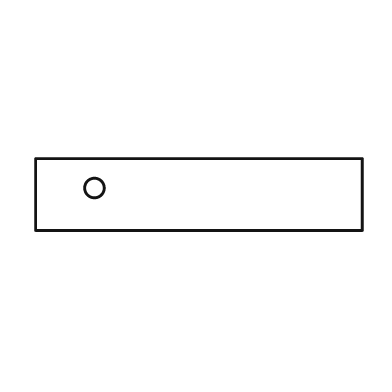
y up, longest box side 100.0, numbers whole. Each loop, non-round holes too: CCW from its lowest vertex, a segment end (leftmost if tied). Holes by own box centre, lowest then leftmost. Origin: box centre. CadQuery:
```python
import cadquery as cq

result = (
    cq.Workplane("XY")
    .moveTo(-50.0, -11.0)
    .lineTo(50.0, -11.0)
    .lineTo(50.0, 11.0)
    .lineTo(-50.0, 11.0)
    .close()
    .moveTo(-32.0, 2.0)
    .circle(3.0)
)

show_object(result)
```